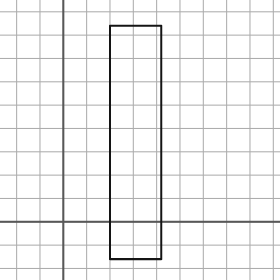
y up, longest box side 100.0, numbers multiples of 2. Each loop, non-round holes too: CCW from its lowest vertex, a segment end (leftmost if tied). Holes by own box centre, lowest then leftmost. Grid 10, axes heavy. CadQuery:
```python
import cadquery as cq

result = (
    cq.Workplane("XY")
    .moveTo(20.0, -16.0)
    .lineTo(42.0, -16.0)
    .lineTo(42.0, 84.0)
    .lineTo(20.0, 84.0)
    .close()
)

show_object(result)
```